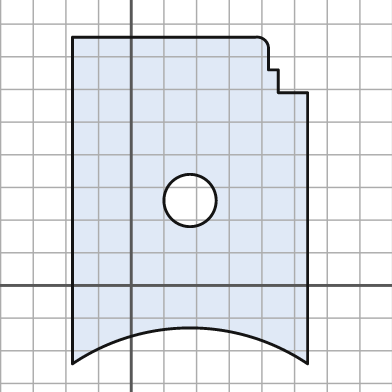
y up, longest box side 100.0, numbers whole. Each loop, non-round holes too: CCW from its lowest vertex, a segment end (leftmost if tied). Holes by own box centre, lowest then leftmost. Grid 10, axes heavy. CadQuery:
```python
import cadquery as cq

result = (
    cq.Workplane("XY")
    .moveTo(-18.0, -24.0)
    .threePointArc((18.0, -13.0), (54.0, -24.0))
    .lineTo(54.0, 59.0)
    .lineTo(45.0, 59.0)
    .lineTo(45.0, 66.0)
    .lineTo(42.0, 66.0)
    .lineTo(42.0, 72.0)
    .threePointArc((41.0, 75.0), (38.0, 76.0))
    .lineTo(-18.0, 76.0)
    .close()
    .moveTo(18.0, 26.0)
    .circle(8.0)
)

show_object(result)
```